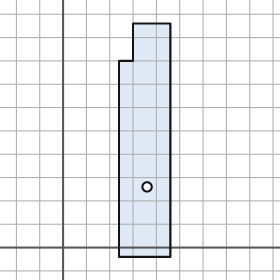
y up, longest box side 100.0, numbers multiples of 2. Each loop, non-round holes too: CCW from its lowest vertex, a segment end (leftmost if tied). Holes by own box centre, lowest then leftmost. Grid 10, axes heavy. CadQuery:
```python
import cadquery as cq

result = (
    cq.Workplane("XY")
    .moveTo(24.0, -4.0)
    .lineTo(46.0, -4.0)
    .lineTo(46.0, 96.0)
    .lineTo(30.0, 96.0)
    .lineTo(30.0, 80.0)
    .lineTo(24.0, 80.0)
    .close()
    .moveTo(36.0, 26.0)
    .circle(2.0)
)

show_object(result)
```